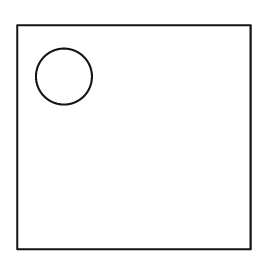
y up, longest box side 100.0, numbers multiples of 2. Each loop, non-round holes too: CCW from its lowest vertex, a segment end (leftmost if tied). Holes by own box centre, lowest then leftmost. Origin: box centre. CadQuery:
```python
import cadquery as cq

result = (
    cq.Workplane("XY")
    .moveTo(-50.0, -48.0)
    .lineTo(50.0, -48.0)
    .lineTo(50.0, 48.0)
    .lineTo(-50.0, 48.0)
    .close()
    .moveTo(-30.0, 26.0)
    .circle(12.0)
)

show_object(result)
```